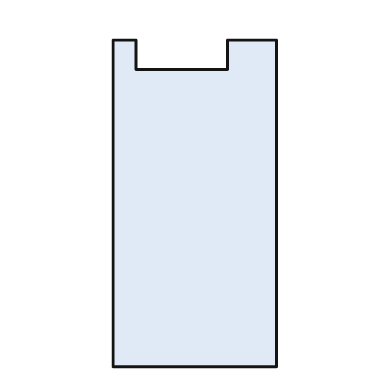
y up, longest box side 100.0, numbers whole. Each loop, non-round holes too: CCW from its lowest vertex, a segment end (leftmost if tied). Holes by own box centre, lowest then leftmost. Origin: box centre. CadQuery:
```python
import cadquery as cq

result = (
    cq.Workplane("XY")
    .moveTo(-25.0, -50.0)
    .lineTo(25.0, -50.0)
    .lineTo(25.0, 50.0)
    .lineTo(10.0, 50.0)
    .lineTo(10.0, 41.0)
    .lineTo(-18.0, 41.0)
    .lineTo(-18.0, 50.0)
    .lineTo(-25.0, 50.0)
    .close()
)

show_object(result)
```